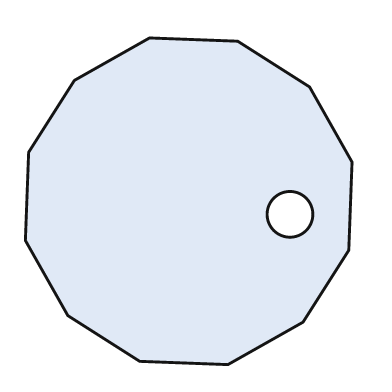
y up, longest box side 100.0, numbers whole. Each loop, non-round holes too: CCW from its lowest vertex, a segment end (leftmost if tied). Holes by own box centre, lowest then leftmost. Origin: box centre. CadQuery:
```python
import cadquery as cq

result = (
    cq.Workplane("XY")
    .moveTo(12.0, -50.0)
    .lineTo(35.0, -37.0)
    .lineTo(49.0, -15.0)
    .lineTo(50.0, 12.0)
    .lineTo(37.0, 35.0)
    .lineTo(15.0, 49.0)
    .lineTo(-12.0, 50.0)
    .lineTo(-35.0, 37.0)
    .lineTo(-49.0, 15.0)
    .lineTo(-50.0, -12.0)
    .lineTo(-37.0, -35.0)
    .lineTo(-15.0, -49.0)
    .close()
    .moveTo(31.0, -4.0)
    .circle(7.0)
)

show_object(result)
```